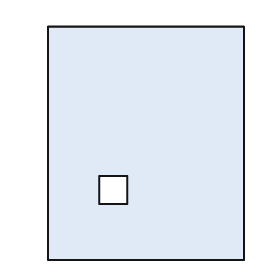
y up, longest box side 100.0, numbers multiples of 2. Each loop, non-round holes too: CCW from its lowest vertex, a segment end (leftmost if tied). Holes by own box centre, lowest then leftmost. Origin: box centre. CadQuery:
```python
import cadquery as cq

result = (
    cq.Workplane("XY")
    .moveTo(-42.0, -50.0)
    .lineTo(42.0, -50.0)
    .lineTo(42.0, 50.0)
    .lineTo(-42.0, 50.0)
    .close()
    .moveTo(-20.0, -26.0)
    .lineTo(-8.0, -26.0)
    .lineTo(-8.0, -14.0)
    .lineTo(-20.0, -14.0)
    .close()
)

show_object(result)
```